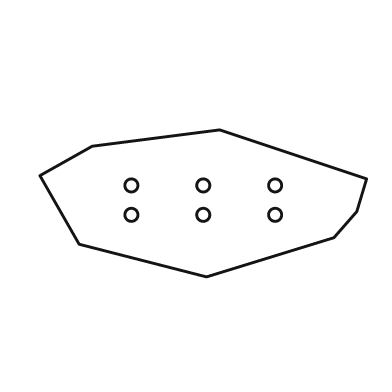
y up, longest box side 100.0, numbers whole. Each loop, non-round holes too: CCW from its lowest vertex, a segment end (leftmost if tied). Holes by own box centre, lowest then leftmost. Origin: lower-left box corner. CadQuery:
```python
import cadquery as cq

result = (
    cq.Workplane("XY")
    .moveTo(51.0, 0.0)
    .lineTo(90.0, 12.0)
    .lineTo(97.0, 20.0)
    .lineTo(100.0, 30.0)
    .lineTo(55.0, 45.0)
    .lineTo(16.0, 40.0)
    .lineTo(0.0, 31.0)
    .lineTo(12.0, 10.0)
    .close()
    .moveTo(28.0, 19.0)
    .circle(2.0)
    .moveTo(50.0, 19.0)
    .circle(2.0)
    .moveTo(72.0, 19.0)
    .circle(2.0)
    .moveTo(28.0, 28.0)
    .circle(2.0)
    .moveTo(50.0, 28.0)
    .circle(2.0)
    .moveTo(72.0, 28.0)
    .circle(2.0)
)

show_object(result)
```